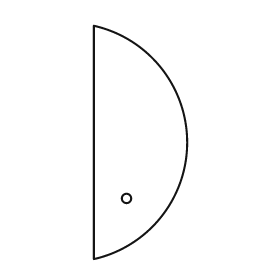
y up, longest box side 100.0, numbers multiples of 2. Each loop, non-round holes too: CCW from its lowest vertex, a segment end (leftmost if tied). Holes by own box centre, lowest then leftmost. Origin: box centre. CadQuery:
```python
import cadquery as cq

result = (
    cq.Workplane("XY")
    .moveTo(-20.0, -50.0)
    .threePointArc((20.0, 0.0), (-20.0, 50.0))
    .close()
    .moveTo(-6.0, -24.0)
    .circle(2.0)
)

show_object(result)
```